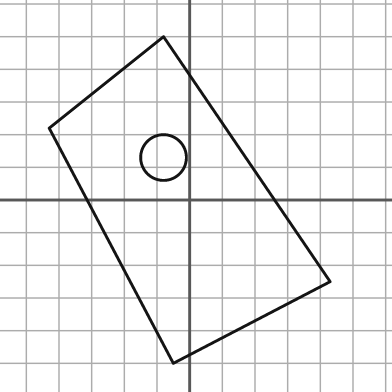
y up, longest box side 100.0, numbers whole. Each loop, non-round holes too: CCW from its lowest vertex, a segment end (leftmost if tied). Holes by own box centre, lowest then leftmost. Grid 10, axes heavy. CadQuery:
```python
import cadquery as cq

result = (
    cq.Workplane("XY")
    .moveTo(-5.0, -50.0)
    .lineTo(43.0, -25.0)
    .lineTo(-8.0, 50.0)
    .lineTo(-43.0, 22.0)
    .close()
    .moveTo(-8.0, 13.0)
    .circle(7.0)
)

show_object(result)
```